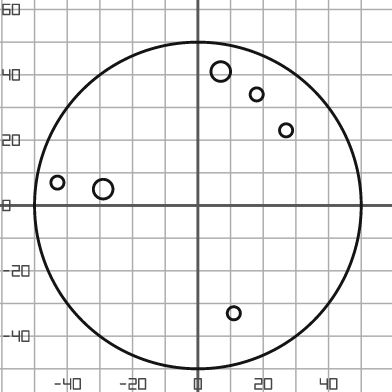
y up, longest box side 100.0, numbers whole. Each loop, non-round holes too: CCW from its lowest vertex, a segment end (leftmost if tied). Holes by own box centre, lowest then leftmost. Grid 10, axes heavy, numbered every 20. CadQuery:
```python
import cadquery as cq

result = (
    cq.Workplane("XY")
    .moveTo(0.0, 0.0)
    .circle(50.0)
    .moveTo(11.0, -33.0)
    .circle(2.0)
    .moveTo(-29.0, 5.0)
    .circle(3.0)
    .moveTo(-43.0, 7.0)
    .circle(2.0)
    .moveTo(27.0, 23.0)
    .circle(2.0)
    .moveTo(18.0, 34.0)
    .circle(2.0)
    .moveTo(7.0, 41.0)
    .circle(3.0)
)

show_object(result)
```